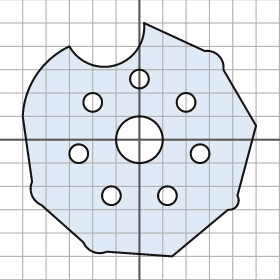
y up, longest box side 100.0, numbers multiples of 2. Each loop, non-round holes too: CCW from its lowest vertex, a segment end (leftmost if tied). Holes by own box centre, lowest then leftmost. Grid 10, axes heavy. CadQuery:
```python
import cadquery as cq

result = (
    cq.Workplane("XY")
    .moveTo(14.0, -50.0)
    .lineTo(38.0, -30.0)
    .threePointArc((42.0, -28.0), (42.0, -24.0))
    .lineTo(50.0, 6.0)
    .lineTo(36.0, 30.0)
    .threePointArc((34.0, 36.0), (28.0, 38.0))
    .lineTo(2.0, 50.0)
    .threePointArc((-10.0, 32.0), (-30.0, 40.0))
    .threePointArc((-44.0, 28.0), (-50.0, 10.0))
    .lineTo(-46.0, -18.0)
    .threePointArc((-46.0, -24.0), (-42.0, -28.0))
    .lineTo(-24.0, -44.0)
    .threePointArc((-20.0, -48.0), (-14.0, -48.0))
    .close()
    .moveTo(-12.0, -24.0)
    .circle(4.0)
    .moveTo(12.0, -24.0)
    .circle(4.0)
    .moveTo(-26.0, -6.0)
    .circle(4.0)
    .moveTo(26.0, -6.0)
    .circle(4.0)
    .moveTo(0.0, 0.0)
    .circle(10.0)
    .moveTo(-20.0, 16.0)
    .circle(4.0)
    .moveTo(20.0, 16.0)
    .circle(4.0)
    .moveTo(0.0, 26.0)
    .circle(4.0)
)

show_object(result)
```